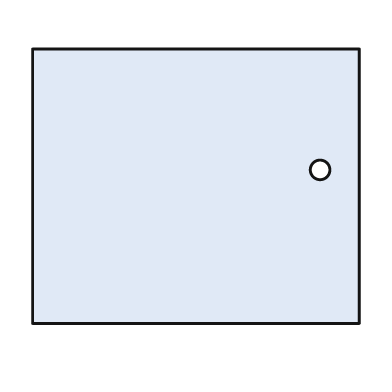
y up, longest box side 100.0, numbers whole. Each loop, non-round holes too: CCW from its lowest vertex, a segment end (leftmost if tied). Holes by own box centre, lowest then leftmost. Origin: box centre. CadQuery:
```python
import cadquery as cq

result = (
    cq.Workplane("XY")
    .moveTo(-50.0, -42.0)
    .lineTo(50.0, -42.0)
    .lineTo(50.0, 42.0)
    .lineTo(-50.0, 42.0)
    .close()
    .moveTo(38.0, 5.0)
    .circle(3.0)
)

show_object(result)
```